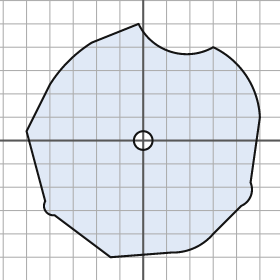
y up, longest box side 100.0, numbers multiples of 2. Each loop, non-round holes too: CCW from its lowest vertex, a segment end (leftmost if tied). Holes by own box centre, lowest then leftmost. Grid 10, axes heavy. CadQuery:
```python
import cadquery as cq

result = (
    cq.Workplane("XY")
    .moveTo(-14.0, -50.0)
    .lineTo(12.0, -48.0)
    .threePointArc((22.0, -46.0), (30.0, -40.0))
    .lineTo(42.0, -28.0)
    .threePointArc((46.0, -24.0), (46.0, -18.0))
    .lineTo(50.0, 10.0)
    .threePointArc((44.0, 28.0), (30.0, 40.0))
    .threePointArc((12.0, 38.0), (-2.0, 50.0))
    .lineTo(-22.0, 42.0)
    .threePointArc((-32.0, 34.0), (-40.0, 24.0))
    .lineTo(-50.0, 4.0)
    .lineTo(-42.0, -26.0)
    .threePointArc((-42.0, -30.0), (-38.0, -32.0))
    .close()
    .moveTo(0.0, 0.0)
    .circle(4.0)
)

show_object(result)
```